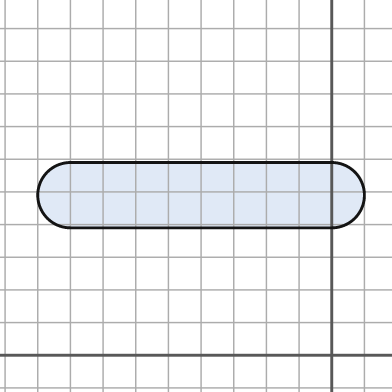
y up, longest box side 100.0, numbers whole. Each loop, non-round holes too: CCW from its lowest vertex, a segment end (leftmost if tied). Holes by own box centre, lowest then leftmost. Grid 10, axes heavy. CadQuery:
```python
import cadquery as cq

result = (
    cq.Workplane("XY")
    .moveTo(-80.0, 39.0)
    .lineTo(0.0, 39.0)
    .threePointArc((10.0, 49.0), (0.0, 59.0))
    .lineTo(-80.0, 59.0)
    .threePointArc((-90.0, 49.0), (-80.0, 39.0))
    .close()
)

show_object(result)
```